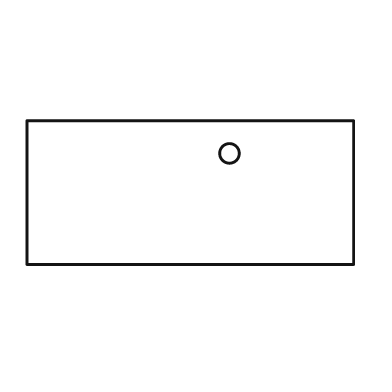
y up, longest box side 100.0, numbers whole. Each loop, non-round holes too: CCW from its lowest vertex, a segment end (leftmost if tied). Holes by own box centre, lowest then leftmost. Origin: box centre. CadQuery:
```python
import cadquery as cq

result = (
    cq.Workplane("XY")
    .moveTo(-50.0, -22.0)
    .lineTo(50.0, -22.0)
    .lineTo(50.0, 22.0)
    .lineTo(-50.0, 22.0)
    .close()
    .moveTo(12.0, 12.0)
    .circle(3.0)
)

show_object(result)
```